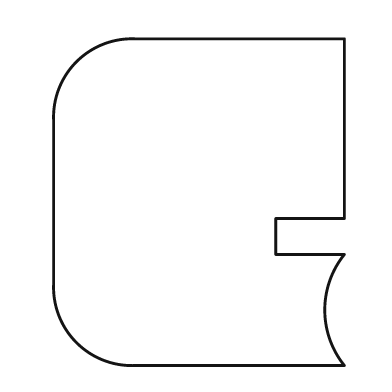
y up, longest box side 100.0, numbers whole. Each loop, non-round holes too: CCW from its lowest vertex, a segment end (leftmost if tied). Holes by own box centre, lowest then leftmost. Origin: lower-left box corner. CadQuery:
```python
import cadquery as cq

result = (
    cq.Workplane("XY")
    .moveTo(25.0, 0.0)
    .lineTo(89.0, 0.0)
    .threePointArc((83.0, 17.0), (89.0, 34.0))
    .lineTo(68.0, 34.0)
    .lineTo(68.0, 45.0)
    .lineTo(89.0, 45.0)
    .lineTo(89.0, 100.0)
    .lineTo(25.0, 100.0)
    .threePointArc((7.0, 93.0), (0.0, 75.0))
    .lineTo(0.0, 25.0)
    .threePointArc((7.0, 7.0), (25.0, 0.0))
    .close()
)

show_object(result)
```